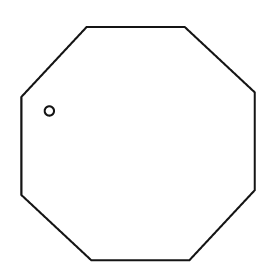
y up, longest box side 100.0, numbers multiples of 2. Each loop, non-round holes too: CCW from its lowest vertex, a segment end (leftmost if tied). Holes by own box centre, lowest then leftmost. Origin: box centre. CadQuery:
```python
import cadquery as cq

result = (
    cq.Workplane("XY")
    .moveTo(-20.0, -50.0)
    .lineTo(22.0, -50.0)
    .lineTo(50.0, -20.0)
    .lineTo(50.0, 22.0)
    .lineTo(20.0, 50.0)
    .lineTo(-22.0, 50.0)
    .lineTo(-50.0, 20.0)
    .lineTo(-50.0, -22.0)
    .close()
    .moveTo(-38.0, 14.0)
    .circle(2.0)
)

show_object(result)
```